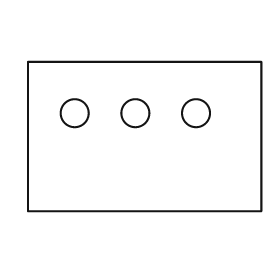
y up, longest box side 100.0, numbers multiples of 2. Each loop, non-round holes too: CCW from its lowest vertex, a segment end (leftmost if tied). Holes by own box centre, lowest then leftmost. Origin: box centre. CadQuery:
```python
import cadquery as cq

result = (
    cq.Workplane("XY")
    .moveTo(-50.0, -32.0)
    .lineTo(50.0, -32.0)
    .lineTo(50.0, 32.0)
    .lineTo(-50.0, 32.0)
    .close()
    .moveTo(-30.0, 10.0)
    .circle(6.0)
    .moveTo(-4.0, 10.0)
    .circle(6.0)
    .moveTo(22.0, 10.0)
    .circle(6.0)
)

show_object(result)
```